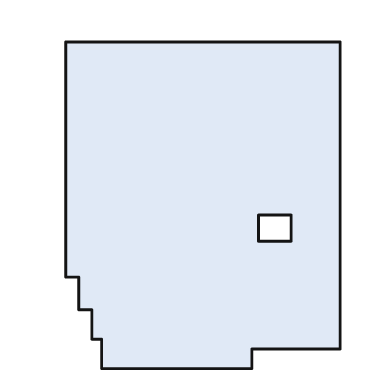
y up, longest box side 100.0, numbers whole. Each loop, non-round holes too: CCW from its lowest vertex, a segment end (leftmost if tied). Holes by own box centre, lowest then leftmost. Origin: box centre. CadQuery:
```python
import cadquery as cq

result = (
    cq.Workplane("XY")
    .moveTo(-31.0, -50.0)
    .lineTo(15.0, -50.0)
    .lineTo(15.0, -44.0)
    .lineTo(42.0, -44.0)
    .lineTo(42.0, 50.0)
    .lineTo(-42.0, 50.0)
    .lineTo(-42.0, -22.0)
    .lineTo(-38.0, -22.0)
    .lineTo(-38.0, -32.0)
    .lineTo(-34.0, -32.0)
    .lineTo(-34.0, -41.0)
    .lineTo(-31.0, -41.0)
    .close()
    .moveTo(17.0, -11.0)
    .lineTo(27.0, -11.0)
    .lineTo(27.0, -3.0)
    .lineTo(17.0, -3.0)
    .close()
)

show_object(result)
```